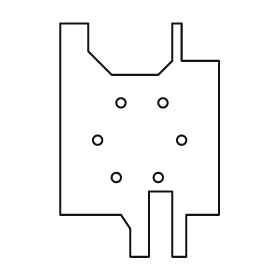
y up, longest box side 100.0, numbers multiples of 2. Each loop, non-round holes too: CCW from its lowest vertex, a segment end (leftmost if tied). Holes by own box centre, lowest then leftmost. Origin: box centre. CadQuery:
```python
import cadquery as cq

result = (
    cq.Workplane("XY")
    .moveTo(-4.0, -50.0)
    .lineTo(4.0, -50.0)
    .lineTo(4.0, -22.0)
    .lineTo(14.0, -22.0)
    .lineTo(14.0, -50.0)
    .lineTo(20.0, -50.0)
    .lineTo(20.0, -32.0)
    .lineTo(34.0, -32.0)
    .lineTo(34.0, 34.0)
    .lineTo(18.0, 34.0)
    .lineTo(18.0, 50.0)
    .lineTo(14.0, 50.0)
    .lineTo(14.0, 34.0)
    .lineTo(8.0, 28.0)
    .lineTo(-12.0, 28.0)
    .lineTo(-22.0, 38.0)
    .lineTo(-22.0, 50.0)
    .lineTo(-34.0, 50.0)
    .lineTo(-34.0, -32.0)
    .lineTo(-8.0, -32.0)
    .lineTo(-4.0, -38.0)
    .close()
    .moveTo(-10.0, -16.0)
    .circle(2.0)
    .moveTo(8.0, -16.0)
    .circle(2.0)
    .moveTo(-18.0, 0.0)
    .circle(2.0)
    .moveTo(18.0, 0.0)
    .circle(2.0)
    .moveTo(-8.0, 16.0)
    .circle(2.0)
    .moveTo(10.0, 16.0)
    .circle(2.0)
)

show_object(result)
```